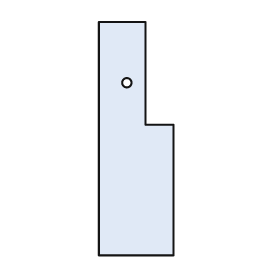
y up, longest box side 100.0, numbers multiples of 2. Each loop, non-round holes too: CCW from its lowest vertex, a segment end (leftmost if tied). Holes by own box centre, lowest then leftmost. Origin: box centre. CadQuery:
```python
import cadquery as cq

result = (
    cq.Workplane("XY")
    .moveTo(-16.0, -50.0)
    .lineTo(16.0, -50.0)
    .lineTo(16.0, 6.0)
    .lineTo(4.0, 6.0)
    .lineTo(4.0, 50.0)
    .lineTo(-16.0, 50.0)
    .close()
    .moveTo(-4.0, 24.0)
    .circle(2.0)
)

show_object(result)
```